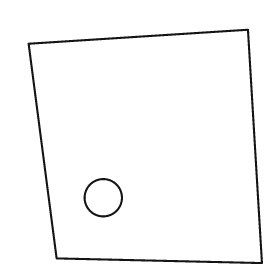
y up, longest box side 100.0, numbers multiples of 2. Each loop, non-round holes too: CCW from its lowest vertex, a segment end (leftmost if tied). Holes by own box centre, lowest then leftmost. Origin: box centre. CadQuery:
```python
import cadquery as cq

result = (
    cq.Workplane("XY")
    .moveTo(50.0, -50.0)
    .lineTo(44.0, 50.0)
    .lineTo(-50.0, 44.0)
    .lineTo(-38.0, -48.0)
    .close()
    .moveTo(-18.0, -22.0)
    .circle(8.0)
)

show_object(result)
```